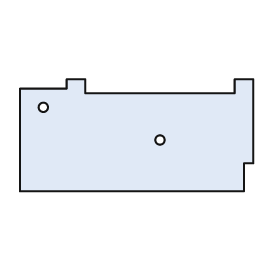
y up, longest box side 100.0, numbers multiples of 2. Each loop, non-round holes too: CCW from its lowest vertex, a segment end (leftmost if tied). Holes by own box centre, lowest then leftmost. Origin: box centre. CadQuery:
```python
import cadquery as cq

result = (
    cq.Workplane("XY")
    .moveTo(-50.0, -24.0)
    .lineTo(46.0, -24.0)
    .lineTo(46.0, -12.0)
    .lineTo(50.0, -12.0)
    .lineTo(50.0, 24.0)
    .lineTo(42.0, 24.0)
    .lineTo(42.0, 18.0)
    .lineTo(-22.0, 18.0)
    .lineTo(-22.0, 24.0)
    .lineTo(-30.0, 24.0)
    .lineTo(-30.0, 20.0)
    .lineTo(-50.0, 20.0)
    .close()
    .moveTo(10.0, -2.0)
    .circle(2.0)
    .moveTo(-40.0, 12.0)
    .circle(2.0)
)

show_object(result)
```